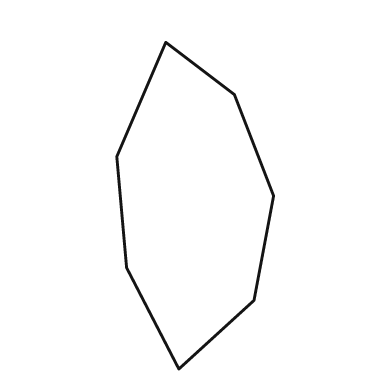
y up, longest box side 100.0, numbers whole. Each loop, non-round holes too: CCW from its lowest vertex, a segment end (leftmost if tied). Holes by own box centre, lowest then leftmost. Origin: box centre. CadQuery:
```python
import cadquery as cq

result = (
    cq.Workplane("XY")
    .moveTo(-5.0, -50.0)
    .lineTo(18.0, -29.0)
    .lineTo(24.0, 3.0)
    .lineTo(12.0, 34.0)
    .lineTo(-9.0, 50.0)
    .lineTo(-24.0, 15.0)
    .lineTo(-21.0, -19.0)
    .close()
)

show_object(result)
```